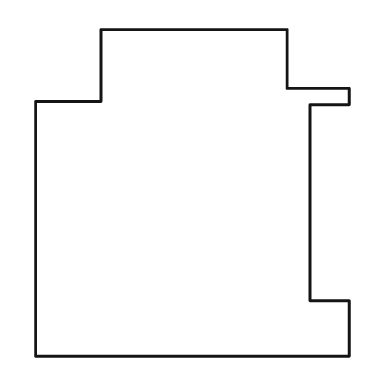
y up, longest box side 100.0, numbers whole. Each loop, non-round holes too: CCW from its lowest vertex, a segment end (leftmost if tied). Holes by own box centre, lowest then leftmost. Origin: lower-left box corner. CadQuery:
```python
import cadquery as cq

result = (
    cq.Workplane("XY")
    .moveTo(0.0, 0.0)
    .lineTo(96.0, 0.0)
    .lineTo(96.0, 17.0)
    .lineTo(84.0, 17.0)
    .lineTo(84.0, 77.0)
    .lineTo(96.0, 77.0)
    .lineTo(96.0, 82.0)
    .lineTo(77.0, 82.0)
    .lineTo(77.0, 100.0)
    .lineTo(20.0, 100.0)
    .lineTo(20.0, 78.0)
    .lineTo(0.0, 78.0)
    .close()
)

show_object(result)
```